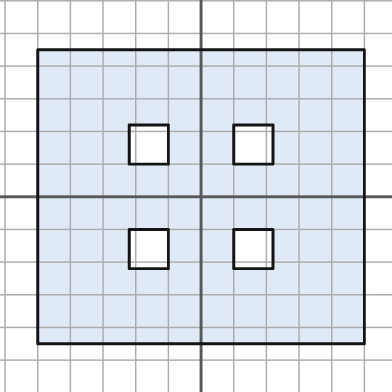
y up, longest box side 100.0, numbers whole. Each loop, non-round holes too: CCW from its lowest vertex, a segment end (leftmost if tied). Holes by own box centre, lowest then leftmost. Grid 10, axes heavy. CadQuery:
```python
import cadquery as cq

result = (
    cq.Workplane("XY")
    .moveTo(-50.0, -45.0)
    .lineTo(50.0, -45.0)
    .lineTo(50.0, 45.0)
    .lineTo(-50.0, 45.0)
    .close()
    .moveTo(-22.0, -22.0)
    .lineTo(-10.0, -22.0)
    .lineTo(-10.0, -10.0)
    .lineTo(-22.0, -10.0)
    .close()
    .moveTo(10.0, -22.0)
    .lineTo(22.0, -22.0)
    .lineTo(22.0, -10.0)
    .lineTo(10.0, -10.0)
    .close()
    .moveTo(-22.0, 10.0)
    .lineTo(-10.0, 10.0)
    .lineTo(-10.0, 22.0)
    .lineTo(-22.0, 22.0)
    .close()
    .moveTo(10.0, 10.0)
    .lineTo(22.0, 10.0)
    .lineTo(22.0, 22.0)
    .lineTo(10.0, 22.0)
    .close()
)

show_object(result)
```